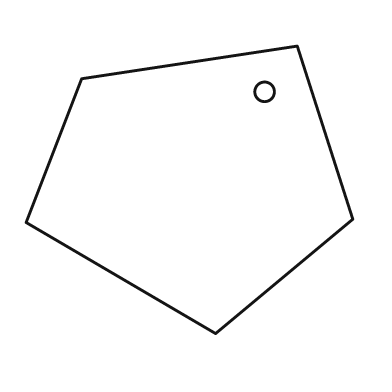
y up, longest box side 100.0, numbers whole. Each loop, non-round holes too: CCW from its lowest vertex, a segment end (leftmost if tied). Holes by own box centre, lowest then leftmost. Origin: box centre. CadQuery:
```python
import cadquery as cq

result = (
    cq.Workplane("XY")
    .moveTo(8.0, -44.0)
    .lineTo(50.0, -9.0)
    .lineTo(33.0, 44.0)
    .lineTo(-33.0, 34.0)
    .lineTo(-50.0, -10.0)
    .close()
    .moveTo(23.0, 30.0)
    .circle(3.0)
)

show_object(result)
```